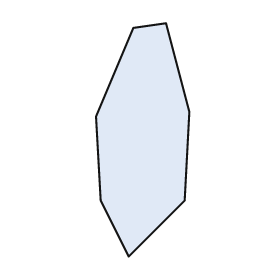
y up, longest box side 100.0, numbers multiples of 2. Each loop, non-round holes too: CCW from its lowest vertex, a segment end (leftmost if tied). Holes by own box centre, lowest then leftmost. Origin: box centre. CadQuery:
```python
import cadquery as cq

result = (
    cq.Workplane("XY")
    .moveTo(-6.0, -50.0)
    .lineTo(18.0, -26.0)
    .lineTo(20.0, 12.0)
    .lineTo(10.0, 50.0)
    .lineTo(-4.0, 48.0)
    .lineTo(-20.0, 10.0)
    .lineTo(-18.0, -26.0)
    .close()
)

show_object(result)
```